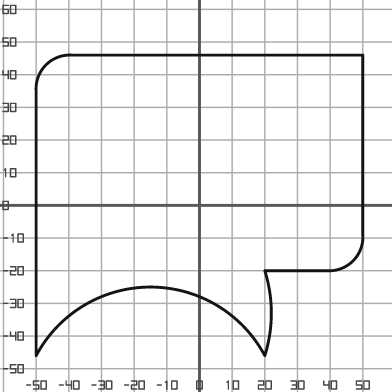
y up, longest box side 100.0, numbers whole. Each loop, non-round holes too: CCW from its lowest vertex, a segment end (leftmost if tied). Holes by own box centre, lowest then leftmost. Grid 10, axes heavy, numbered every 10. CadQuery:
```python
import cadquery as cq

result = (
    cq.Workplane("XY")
    .moveTo(-50.0, -46.0)
    .threePointArc((-15.0, -25.0), (20.0, -46.0))
    .threePointArc((22.0, -33.0), (20.0, -20.0))
    .lineTo(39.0, -20.0)
    .threePointArc((47.0, -17.0), (50.0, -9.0))
    .lineTo(50.0, 46.0)
    .lineTo(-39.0, 46.0)
    .threePointArc((-47.0, 43.0), (-50.0, 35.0))
    .close()
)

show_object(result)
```